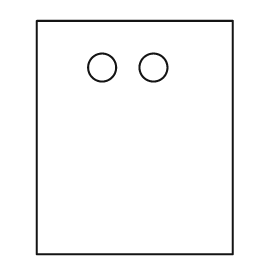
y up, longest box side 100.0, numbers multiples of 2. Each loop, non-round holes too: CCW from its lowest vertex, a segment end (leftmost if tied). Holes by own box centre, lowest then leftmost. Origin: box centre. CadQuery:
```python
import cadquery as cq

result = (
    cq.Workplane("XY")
    .moveTo(-42.0, -50.0)
    .lineTo(42.0, -50.0)
    .lineTo(42.0, 50.0)
    .lineTo(-42.0, 50.0)
    .close()
    .moveTo(-14.0, 30.0)
    .circle(6.0)
    .moveTo(8.0, 30.0)
    .circle(6.0)
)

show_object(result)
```